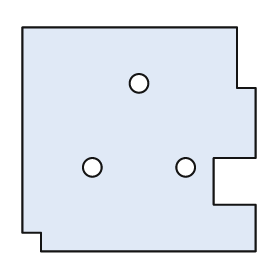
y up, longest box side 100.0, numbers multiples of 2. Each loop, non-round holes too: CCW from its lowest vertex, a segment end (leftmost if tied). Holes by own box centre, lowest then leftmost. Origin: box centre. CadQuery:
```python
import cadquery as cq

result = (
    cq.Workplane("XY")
    .moveTo(-42.0, -48.0)
    .lineTo(50.0, -48.0)
    .lineTo(50.0, -28.0)
    .lineTo(32.0, -28.0)
    .lineTo(32.0, -8.0)
    .lineTo(50.0, -8.0)
    .lineTo(50.0, 22.0)
    .lineTo(42.0, 22.0)
    .lineTo(42.0, 48.0)
    .lineTo(-50.0, 48.0)
    .lineTo(-50.0, -40.0)
    .lineTo(-42.0, -40.0)
    .close()
    .moveTo(-20.0, -12.0)
    .circle(4.0)
    .moveTo(20.0, -12.0)
    .circle(4.0)
    .moveTo(0.0, 24.0)
    .circle(4.0)
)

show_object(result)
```